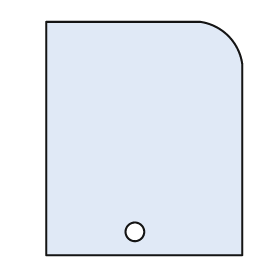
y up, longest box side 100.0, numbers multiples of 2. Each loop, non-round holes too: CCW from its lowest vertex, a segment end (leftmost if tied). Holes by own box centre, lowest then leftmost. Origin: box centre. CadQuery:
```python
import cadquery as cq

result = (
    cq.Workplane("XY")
    .moveTo(-42.0, -50.0)
    .lineTo(42.0, -50.0)
    .lineTo(42.0, 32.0)
    .threePointArc((36.0, 44.0), (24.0, 50.0))
    .lineTo(-42.0, 50.0)
    .close()
    .moveTo(-4.0, -40.0)
    .circle(4.0)
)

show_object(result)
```